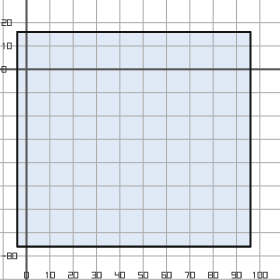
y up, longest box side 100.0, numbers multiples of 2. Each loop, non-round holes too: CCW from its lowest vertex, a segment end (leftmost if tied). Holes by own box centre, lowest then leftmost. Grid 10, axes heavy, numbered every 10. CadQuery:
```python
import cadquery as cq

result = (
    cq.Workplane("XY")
    .moveTo(-4.0, -76.0)
    .lineTo(96.0, -76.0)
    .lineTo(96.0, 16.0)
    .lineTo(-4.0, 16.0)
    .close()
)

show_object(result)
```